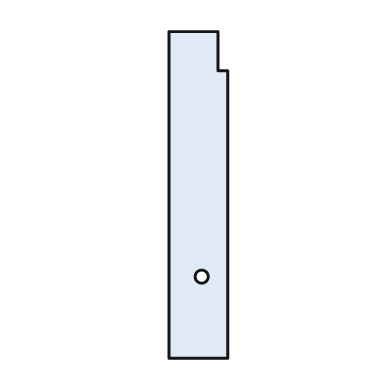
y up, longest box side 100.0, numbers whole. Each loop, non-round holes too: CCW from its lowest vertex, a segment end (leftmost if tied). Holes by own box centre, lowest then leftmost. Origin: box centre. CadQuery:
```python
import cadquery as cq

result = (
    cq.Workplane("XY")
    .moveTo(-9.0, -50.0)
    .lineTo(9.0, -50.0)
    .lineTo(9.0, 38.0)
    .lineTo(6.0, 38.0)
    .lineTo(6.0, 50.0)
    .lineTo(-9.0, 50.0)
    .close()
    .moveTo(1.0, -25.0)
    .circle(2.0)
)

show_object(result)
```